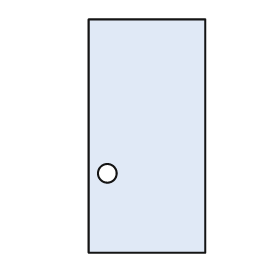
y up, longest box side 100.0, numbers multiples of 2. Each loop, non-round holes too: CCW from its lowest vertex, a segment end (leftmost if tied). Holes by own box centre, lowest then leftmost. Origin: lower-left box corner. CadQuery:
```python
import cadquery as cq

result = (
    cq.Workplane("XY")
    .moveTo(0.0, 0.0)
    .lineTo(50.0, 0.0)
    .lineTo(50.0, 100.0)
    .lineTo(0.0, 100.0)
    .close()
    .moveTo(8.0, 34.0)
    .circle(4.0)
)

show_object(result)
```